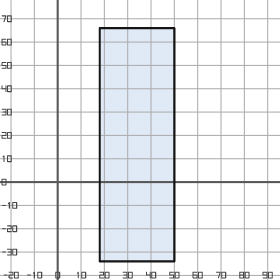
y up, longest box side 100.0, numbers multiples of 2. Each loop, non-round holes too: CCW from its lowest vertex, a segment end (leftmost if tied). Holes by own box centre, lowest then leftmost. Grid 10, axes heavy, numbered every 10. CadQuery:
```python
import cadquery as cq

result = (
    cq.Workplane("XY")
    .moveTo(18.0, -34.0)
    .lineTo(50.0, -34.0)
    .lineTo(50.0, 66.0)
    .lineTo(18.0, 66.0)
    .close()
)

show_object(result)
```